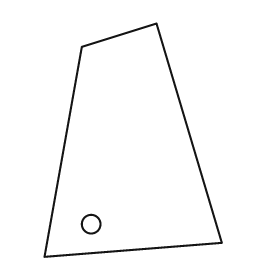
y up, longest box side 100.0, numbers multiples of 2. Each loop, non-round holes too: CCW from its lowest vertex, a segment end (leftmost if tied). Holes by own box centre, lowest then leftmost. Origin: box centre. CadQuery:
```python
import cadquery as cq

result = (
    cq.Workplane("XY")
    .moveTo(-38.0, -50.0)
    .lineTo(38.0, -44.0)
    .lineTo(10.0, 50.0)
    .lineTo(-22.0, 40.0)
    .close()
    .moveTo(-18.0, -36.0)
    .circle(4.0)
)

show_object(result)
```